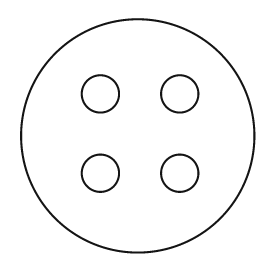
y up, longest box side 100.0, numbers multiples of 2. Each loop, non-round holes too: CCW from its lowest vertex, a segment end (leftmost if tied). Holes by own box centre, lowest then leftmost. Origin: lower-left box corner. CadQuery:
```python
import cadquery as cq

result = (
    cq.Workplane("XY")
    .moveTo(50.0, 50.0)
    .circle(50.0)
    .moveTo(34.0, 34.0)
    .circle(8.0)
    .moveTo(68.0, 34.0)
    .circle(8.0)
    .moveTo(34.0, 68.0)
    .circle(8.0)
    .moveTo(68.0, 68.0)
    .circle(8.0)
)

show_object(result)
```